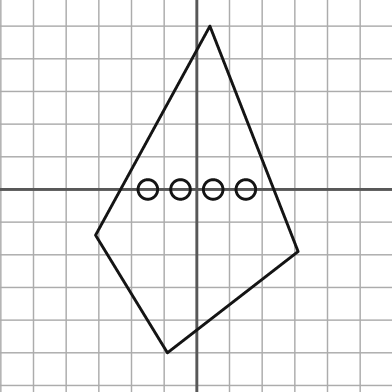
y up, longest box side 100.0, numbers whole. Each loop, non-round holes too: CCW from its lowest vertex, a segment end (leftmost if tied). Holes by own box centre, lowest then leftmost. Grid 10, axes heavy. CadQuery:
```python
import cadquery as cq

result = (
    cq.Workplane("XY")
    .moveTo(-9.0, -50.0)
    .lineTo(31.0, -19.0)
    .lineTo(4.0, 50.0)
    .lineTo(-31.0, -14.0)
    .close()
    .moveTo(-15.0, 0.0)
    .circle(3.0)
    .moveTo(-5.0, 0.0)
    .circle(3.0)
    .moveTo(5.0, 0.0)
    .circle(3.0)
    .moveTo(15.0, 0.0)
    .circle(3.0)
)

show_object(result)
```